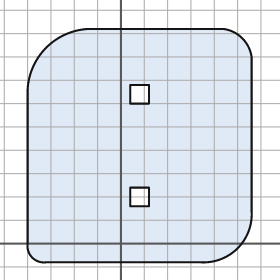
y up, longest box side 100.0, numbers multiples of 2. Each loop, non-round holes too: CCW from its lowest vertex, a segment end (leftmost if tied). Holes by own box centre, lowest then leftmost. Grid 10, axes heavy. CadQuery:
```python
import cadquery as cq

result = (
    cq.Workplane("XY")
    .moveTo(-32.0, -8.0)
    .lineTo(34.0, -8.0)
    .threePointArc((50.0, -2.0), (56.0, 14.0))
    .lineTo(56.0, 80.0)
    .threePointArc((52.0, 88.0), (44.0, 92.0))
    .lineTo(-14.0, 92.0)
    .threePointArc((-32.0, 84.0), (-40.0, 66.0))
    .lineTo(-40.0, 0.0)
    .threePointArc((-38.0, -6.0), (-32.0, -8.0))
    .close()
    .moveTo(4.0, 16.0)
    .lineTo(12.0, 16.0)
    .lineTo(12.0, 24.0)
    .lineTo(4.0, 24.0)
    .close()
    .moveTo(4.0, 60.0)
    .lineTo(12.0, 60.0)
    .lineTo(12.0, 68.0)
    .lineTo(4.0, 68.0)
    .close()
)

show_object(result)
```